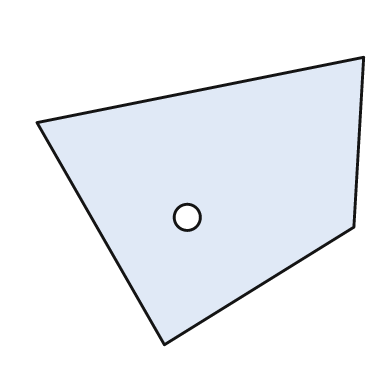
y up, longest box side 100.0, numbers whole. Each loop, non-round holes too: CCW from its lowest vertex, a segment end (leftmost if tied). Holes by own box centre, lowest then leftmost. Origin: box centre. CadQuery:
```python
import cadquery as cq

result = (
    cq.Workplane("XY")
    .moveTo(-11.0, -44.0)
    .lineTo(47.0, -8.0)
    .lineTo(50.0, 44.0)
    .lineTo(-50.0, 24.0)
    .close()
    .moveTo(-4.0, -5.0)
    .circle(4.0)
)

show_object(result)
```